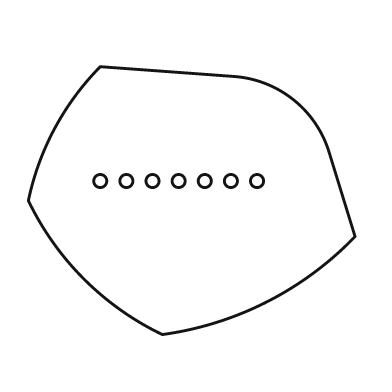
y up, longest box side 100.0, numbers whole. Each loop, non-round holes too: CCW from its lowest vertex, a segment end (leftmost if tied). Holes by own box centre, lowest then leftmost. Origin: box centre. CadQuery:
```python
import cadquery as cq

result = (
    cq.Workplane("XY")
    .moveTo(-9.0, -41.0)
    .threePointArc((23.0, -31.0), (50.0, -11.0))
    .lineTo(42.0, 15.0)
    .threePointArc((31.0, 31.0), (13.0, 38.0))
    .lineTo(-28.0, 41.0)
    .threePointArc((-42.0, 22.0), (-50.0, 0.0))
    .threePointArc((-33.0, -24.0), (-9.0, -41.0))
    .close()
    .moveTo(-28.0, 6.0)
    .circle(2.0)
    .moveTo(-20.0, 6.0)
    .circle(2.0)
    .moveTo(-12.0, 6.0)
    .circle(2.0)
    .moveTo(-4.0, 6.0)
    .circle(2.0)
    .moveTo(4.0, 6.0)
    .circle(2.0)
    .moveTo(12.0, 6.0)
    .circle(2.0)
    .moveTo(20.0, 6.0)
    .circle(2.0)
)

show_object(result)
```